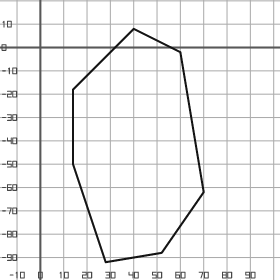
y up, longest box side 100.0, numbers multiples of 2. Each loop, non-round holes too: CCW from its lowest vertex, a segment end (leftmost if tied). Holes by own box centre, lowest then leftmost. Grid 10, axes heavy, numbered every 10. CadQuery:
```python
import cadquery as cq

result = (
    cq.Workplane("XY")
    .moveTo(28.0, -92.0)
    .lineTo(52.0, -88.0)
    .lineTo(70.0, -62.0)
    .lineTo(60.0, -2.0)
    .lineTo(40.0, 8.0)
    .lineTo(14.0, -18.0)
    .lineTo(14.0, -50.0)
    .close()
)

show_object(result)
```